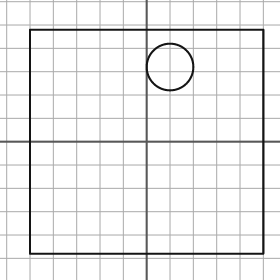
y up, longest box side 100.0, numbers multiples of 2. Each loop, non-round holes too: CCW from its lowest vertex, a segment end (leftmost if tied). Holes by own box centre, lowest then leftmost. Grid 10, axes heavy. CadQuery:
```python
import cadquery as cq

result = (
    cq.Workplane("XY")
    .moveTo(-50.0, -48.0)
    .lineTo(50.0, -48.0)
    .lineTo(50.0, 48.0)
    .lineTo(-50.0, 48.0)
    .close()
    .moveTo(10.0, 32.0)
    .circle(10.0)
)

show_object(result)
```